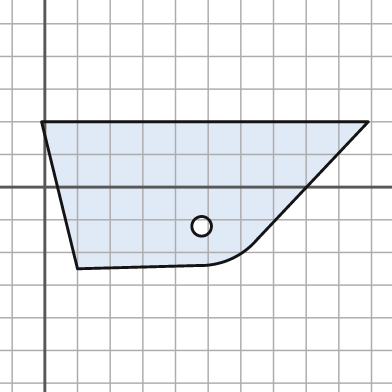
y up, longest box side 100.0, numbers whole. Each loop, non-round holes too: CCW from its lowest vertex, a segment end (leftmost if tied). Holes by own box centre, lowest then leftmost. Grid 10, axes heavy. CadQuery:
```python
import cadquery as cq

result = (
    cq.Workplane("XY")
    .moveTo(10.0, -25.0)
    .lineTo(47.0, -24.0)
    .threePointArc((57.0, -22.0), (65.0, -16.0))
    .lineTo(99.0, 20.0)
    .lineTo(-1.0, 20.0)
    .close()
    .moveTo(48.0, -12.0)
    .circle(3.0)
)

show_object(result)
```